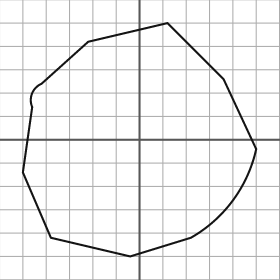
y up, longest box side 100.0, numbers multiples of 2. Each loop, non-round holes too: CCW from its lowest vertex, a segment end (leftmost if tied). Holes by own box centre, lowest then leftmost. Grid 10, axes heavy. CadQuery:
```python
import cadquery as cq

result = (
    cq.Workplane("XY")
    .moveTo(-4.0, -50.0)
    .lineTo(22.0, -42.0)
    .threePointArc((40.0, -26.0), (50.0, -4.0))
    .lineTo(36.0, 26.0)
    .lineTo(12.0, 50.0)
    .lineTo(-22.0, 42.0)
    .lineTo(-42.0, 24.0)
    .threePointArc((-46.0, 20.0), (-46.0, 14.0))
    .lineTo(-50.0, -14.0)
    .lineTo(-38.0, -42.0)
    .close()
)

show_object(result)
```